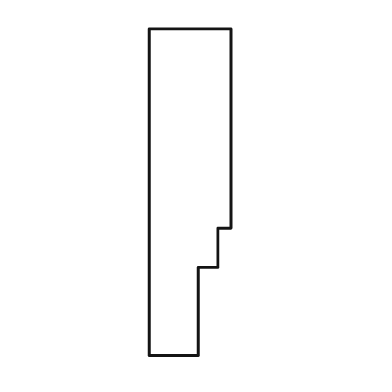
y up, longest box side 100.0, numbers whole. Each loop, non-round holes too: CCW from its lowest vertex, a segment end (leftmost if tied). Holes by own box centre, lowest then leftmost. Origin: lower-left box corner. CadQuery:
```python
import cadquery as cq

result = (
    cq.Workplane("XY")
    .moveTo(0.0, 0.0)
    .lineTo(15.0, 0.0)
    .lineTo(15.0, 27.0)
    .lineTo(21.0, 27.0)
    .lineTo(21.0, 39.0)
    .lineTo(25.0, 39.0)
    .lineTo(25.0, 100.0)
    .lineTo(0.0, 100.0)
    .close()
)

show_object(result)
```